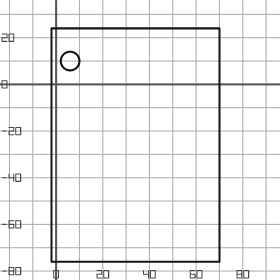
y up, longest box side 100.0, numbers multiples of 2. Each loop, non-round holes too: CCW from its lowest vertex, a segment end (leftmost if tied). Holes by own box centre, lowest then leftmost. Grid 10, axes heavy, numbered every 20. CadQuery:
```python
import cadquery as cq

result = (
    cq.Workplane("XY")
    .moveTo(-2.0, -76.0)
    .lineTo(70.0, -76.0)
    .lineTo(70.0, 24.0)
    .lineTo(-2.0, 24.0)
    .close()
    .moveTo(6.0, 10.0)
    .circle(4.0)
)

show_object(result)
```